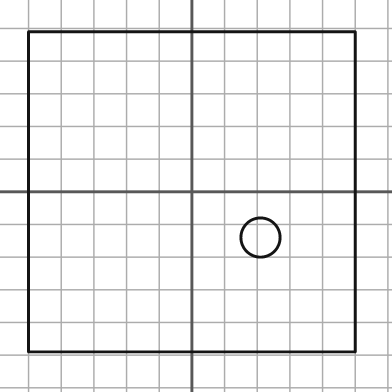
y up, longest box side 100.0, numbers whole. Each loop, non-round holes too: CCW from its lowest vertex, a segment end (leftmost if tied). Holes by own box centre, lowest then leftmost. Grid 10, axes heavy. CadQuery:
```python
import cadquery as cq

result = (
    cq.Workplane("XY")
    .moveTo(-50.0, -49.0)
    .lineTo(50.0, -49.0)
    .lineTo(50.0, 49.0)
    .lineTo(-50.0, 49.0)
    .close()
    .moveTo(21.0, -14.0)
    .circle(6.0)
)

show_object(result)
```